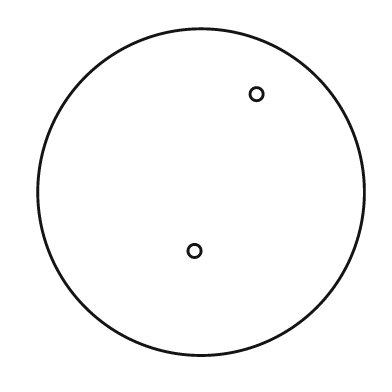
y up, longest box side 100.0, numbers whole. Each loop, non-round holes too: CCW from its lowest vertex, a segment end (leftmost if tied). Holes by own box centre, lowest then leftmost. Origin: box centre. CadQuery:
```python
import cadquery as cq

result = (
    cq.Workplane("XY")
    .moveTo(0.0, 0.0)
    .circle(50.0)
    .moveTo(-2.0, -18.0)
    .circle(2.0)
    .moveTo(17.0, 30.0)
    .circle(2.0)
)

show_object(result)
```